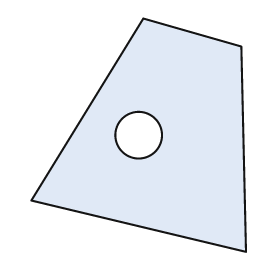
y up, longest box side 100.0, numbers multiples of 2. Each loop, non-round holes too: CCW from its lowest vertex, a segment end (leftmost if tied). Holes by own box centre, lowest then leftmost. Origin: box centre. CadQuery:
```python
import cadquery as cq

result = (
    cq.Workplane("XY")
    .moveTo(46.0, -50.0)
    .lineTo(44.0, 38.0)
    .lineTo(2.0, 50.0)
    .lineTo(-46.0, -28.0)
    .close()
    .moveTo(0.0, 0.0)
    .circle(10.0)
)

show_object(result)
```